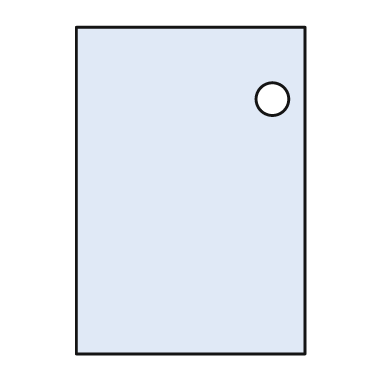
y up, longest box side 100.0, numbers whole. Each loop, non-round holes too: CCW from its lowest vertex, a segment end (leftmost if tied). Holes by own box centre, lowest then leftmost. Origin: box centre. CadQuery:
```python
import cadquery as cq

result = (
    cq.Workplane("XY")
    .moveTo(-35.0, -50.0)
    .lineTo(35.0, -50.0)
    .lineTo(35.0, 50.0)
    .lineTo(-35.0, 50.0)
    .close()
    .moveTo(25.0, 28.0)
    .circle(5.0)
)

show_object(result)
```